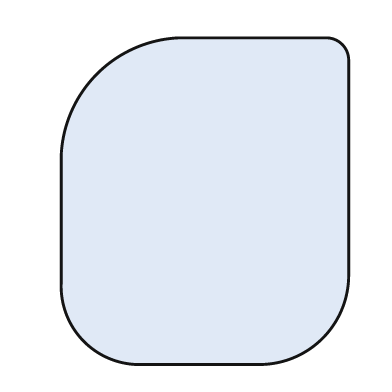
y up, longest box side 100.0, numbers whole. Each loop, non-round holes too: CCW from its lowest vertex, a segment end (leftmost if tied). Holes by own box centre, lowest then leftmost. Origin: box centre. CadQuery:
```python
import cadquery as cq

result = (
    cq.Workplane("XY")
    .moveTo(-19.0, -50.0)
    .lineTo(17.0, -50.0)
    .threePointArc((36.0, -42.0), (44.0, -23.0))
    .lineTo(44.0, 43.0)
    .threePointArc((42.0, 48.0), (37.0, 50.0))
    .lineTo(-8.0, 50.0)
    .threePointArc((-33.0, 39.0), (-44.0, 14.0))
    .lineTo(-44.0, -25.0)
    .threePointArc((-37.0, -43.0), (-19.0, -50.0))
    .close()
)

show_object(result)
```